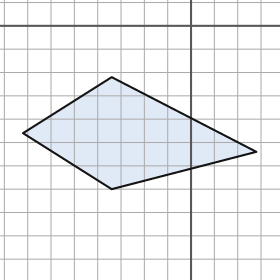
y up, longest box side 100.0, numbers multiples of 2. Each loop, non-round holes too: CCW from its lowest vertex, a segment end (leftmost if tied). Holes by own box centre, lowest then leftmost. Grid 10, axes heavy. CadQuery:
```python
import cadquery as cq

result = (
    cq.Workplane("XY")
    .moveTo(-34.0, -70.0)
    .lineTo(28.0, -54.0)
    .lineTo(-34.0, -22.0)
    .lineTo(-72.0, -46.0)
    .close()
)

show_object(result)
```